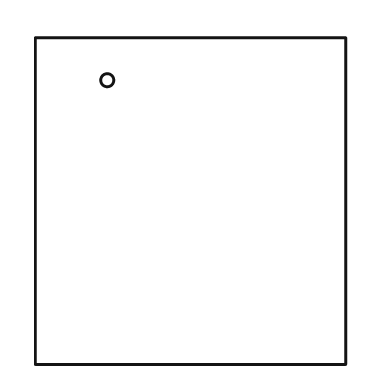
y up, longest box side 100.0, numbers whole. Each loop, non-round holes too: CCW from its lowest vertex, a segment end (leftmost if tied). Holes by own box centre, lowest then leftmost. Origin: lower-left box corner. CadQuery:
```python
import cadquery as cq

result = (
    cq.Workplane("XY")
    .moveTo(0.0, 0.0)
    .lineTo(95.0, 0.0)
    .lineTo(95.0, 100.0)
    .lineTo(0.0, 100.0)
    .close()
    .moveTo(22.0, 87.0)
    .circle(2.0)
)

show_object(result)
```